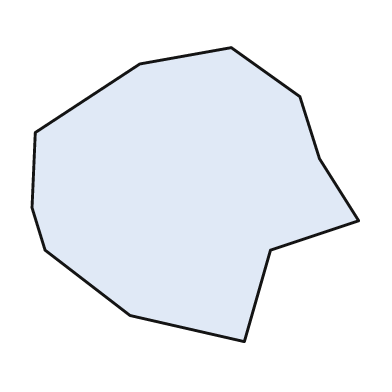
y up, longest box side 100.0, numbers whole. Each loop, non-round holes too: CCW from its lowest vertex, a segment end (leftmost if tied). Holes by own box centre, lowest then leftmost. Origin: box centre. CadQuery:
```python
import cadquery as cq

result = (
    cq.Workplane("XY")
    .moveTo(15.0, -45.0)
    .lineTo(23.0, -17.0)
    .lineTo(50.0, -8.0)
    .lineTo(38.0, 11.0)
    .lineTo(32.0, 30.0)
    .lineTo(11.0, 45.0)
    .lineTo(-17.0, 40.0)
    .lineTo(-49.0, 19.0)
    .lineTo(-50.0, -4.0)
    .lineTo(-46.0, -17.0)
    .lineTo(-20.0, -37.0)
    .close()
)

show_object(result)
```